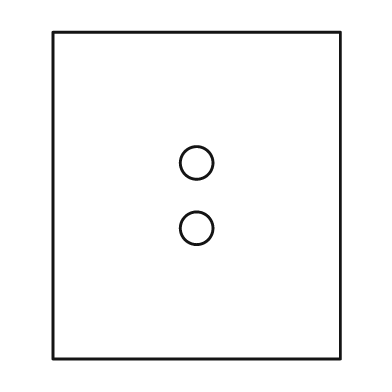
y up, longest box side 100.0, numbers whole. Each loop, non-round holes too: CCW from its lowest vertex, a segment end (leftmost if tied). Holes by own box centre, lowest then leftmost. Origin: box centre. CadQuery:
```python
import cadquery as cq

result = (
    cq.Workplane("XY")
    .moveTo(-44.0, -50.0)
    .lineTo(44.0, -50.0)
    .lineTo(44.0, 50.0)
    .lineTo(-44.0, 50.0)
    .close()
    .moveTo(0.0, -10.0)
    .circle(5.0)
    .moveTo(0.0, 10.0)
    .circle(5.0)
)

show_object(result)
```